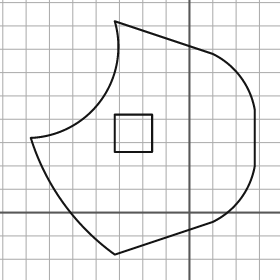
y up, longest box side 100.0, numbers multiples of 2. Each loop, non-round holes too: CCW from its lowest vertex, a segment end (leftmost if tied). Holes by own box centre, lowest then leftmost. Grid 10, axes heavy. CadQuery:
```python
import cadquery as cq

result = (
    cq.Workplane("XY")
    .moveTo(-32.0, -18.0)
    .lineTo(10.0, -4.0)
    .threePointArc((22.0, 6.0), (28.0, 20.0))
    .lineTo(28.0, 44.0)
    .threePointArc((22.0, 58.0), (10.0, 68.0))
    .lineTo(-32.0, 82.0)
    .threePointArc((-38.0, 48.0), (-68.0, 32.0))
    .threePointArc((-54.0, 4.0), (-32.0, -18.0))
    .close()
    .moveTo(-32.0, 26.0)
    .lineTo(-16.0, 26.0)
    .lineTo(-16.0, 42.0)
    .lineTo(-32.0, 42.0)
    .close()
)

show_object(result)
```